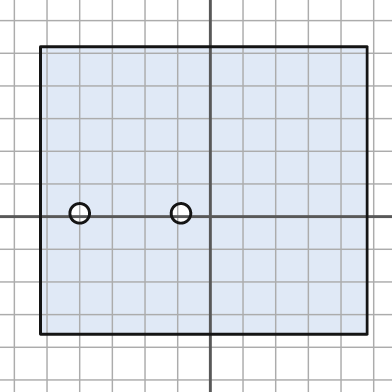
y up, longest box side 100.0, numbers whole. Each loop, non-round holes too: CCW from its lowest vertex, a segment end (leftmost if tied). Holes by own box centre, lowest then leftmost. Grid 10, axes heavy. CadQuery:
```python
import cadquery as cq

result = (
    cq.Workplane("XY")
    .moveTo(-52.0, -36.0)
    .lineTo(48.0, -36.0)
    .lineTo(48.0, 52.0)
    .lineTo(-52.0, 52.0)
    .close()
    .moveTo(-40.0, 1.0)
    .circle(3.0)
    .moveTo(-9.0, 1.0)
    .circle(3.0)
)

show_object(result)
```